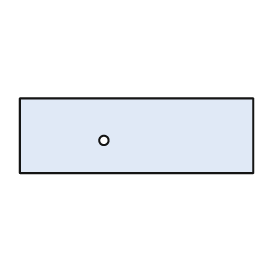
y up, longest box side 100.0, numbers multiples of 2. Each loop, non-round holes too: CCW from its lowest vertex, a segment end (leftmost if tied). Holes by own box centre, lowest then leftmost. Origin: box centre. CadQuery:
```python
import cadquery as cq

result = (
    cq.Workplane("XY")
    .moveTo(-50.0, -16.0)
    .lineTo(50.0, -16.0)
    .lineTo(50.0, 16.0)
    .lineTo(-50.0, 16.0)
    .close()
    .moveTo(-14.0, -2.0)
    .circle(2.0)
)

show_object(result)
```